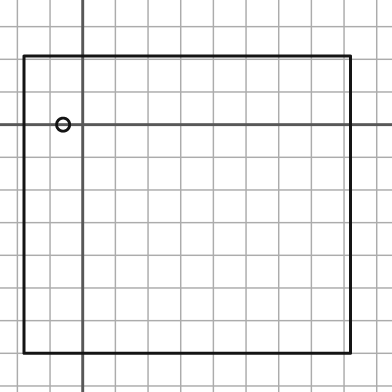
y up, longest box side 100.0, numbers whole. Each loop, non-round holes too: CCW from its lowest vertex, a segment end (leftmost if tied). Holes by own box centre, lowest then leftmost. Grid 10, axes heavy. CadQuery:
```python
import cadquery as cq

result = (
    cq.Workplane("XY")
    .moveTo(-18.0, -70.0)
    .lineTo(82.0, -70.0)
    .lineTo(82.0, 21.0)
    .lineTo(-18.0, 21.0)
    .close()
    .moveTo(-6.0, 0.0)
    .circle(2.0)
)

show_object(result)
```